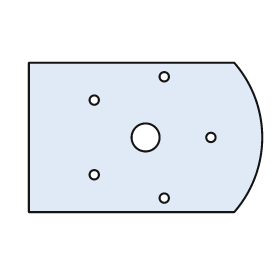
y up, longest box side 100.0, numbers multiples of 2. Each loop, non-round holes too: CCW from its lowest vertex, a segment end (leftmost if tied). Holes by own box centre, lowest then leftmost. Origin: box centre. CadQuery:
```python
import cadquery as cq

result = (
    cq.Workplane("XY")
    .moveTo(-50.0, -32.0)
    .lineTo(38.0, -32.0)
    .threePointArc((50.0, 0.0), (38.0, 32.0))
    .lineTo(-50.0, 32.0)
    .close()
    .moveTo(8.0, -26.0)
    .circle(2.0)
    .moveTo(-22.0, -16.0)
    .circle(2.0)
    .moveTo(0.0, 0.0)
    .circle(6.0)
    .moveTo(28.0, 0.0)
    .circle(2.0)
    .moveTo(-22.0, 16.0)
    .circle(2.0)
    .moveTo(8.0, 26.0)
    .circle(2.0)
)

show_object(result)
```